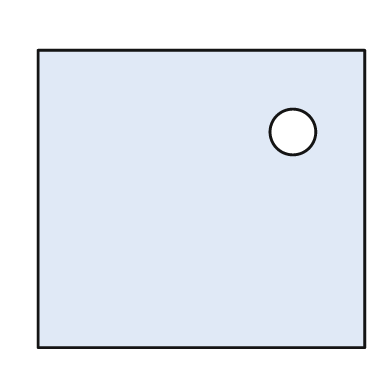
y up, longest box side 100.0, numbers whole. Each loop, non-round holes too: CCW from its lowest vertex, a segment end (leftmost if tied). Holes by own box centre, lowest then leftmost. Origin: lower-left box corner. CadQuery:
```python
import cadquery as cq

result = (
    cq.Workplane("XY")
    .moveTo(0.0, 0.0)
    .lineTo(100.0, 0.0)
    .lineTo(100.0, 91.0)
    .lineTo(0.0, 91.0)
    .close()
    .moveTo(78.0, 66.0)
    .circle(7.0)
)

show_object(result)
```